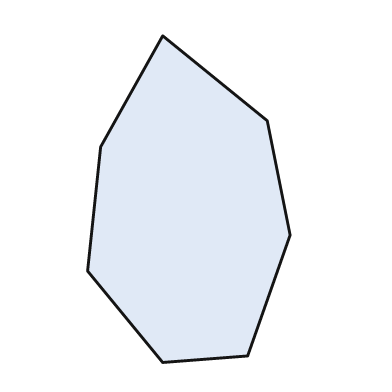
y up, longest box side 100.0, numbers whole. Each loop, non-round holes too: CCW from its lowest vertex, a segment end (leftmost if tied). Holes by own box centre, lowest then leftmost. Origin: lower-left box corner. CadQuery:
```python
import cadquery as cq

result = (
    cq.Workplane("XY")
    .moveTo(23.0, 0.0)
    .lineTo(49.0, 2.0)
    .lineTo(62.0, 39.0)
    .lineTo(55.0, 74.0)
    .lineTo(23.0, 100.0)
    .lineTo(4.0, 66.0)
    .lineTo(0.0, 28.0)
    .close()
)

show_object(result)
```